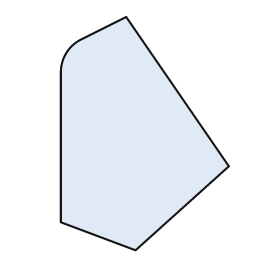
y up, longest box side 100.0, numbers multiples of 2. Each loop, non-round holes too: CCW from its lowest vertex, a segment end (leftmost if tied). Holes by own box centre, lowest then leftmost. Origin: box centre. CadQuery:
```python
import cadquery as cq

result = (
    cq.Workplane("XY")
    .moveTo(-4.0, -50.0)
    .lineTo(36.0, -14.0)
    .lineTo(-8.0, 50.0)
    .lineTo(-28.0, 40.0)
    .threePointArc((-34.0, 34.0), (-36.0, 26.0))
    .lineTo(-36.0, -38.0)
    .close()
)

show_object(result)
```